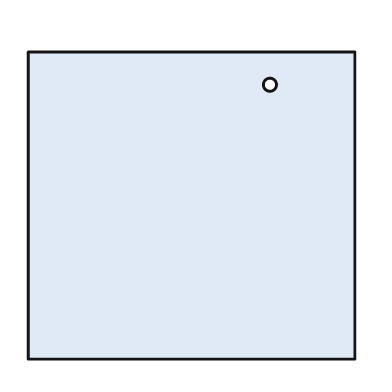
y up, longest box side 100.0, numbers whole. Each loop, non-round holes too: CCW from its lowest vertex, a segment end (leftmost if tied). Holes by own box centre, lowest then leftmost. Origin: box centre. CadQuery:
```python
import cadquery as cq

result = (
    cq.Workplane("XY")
    .moveTo(-50.0, -47.0)
    .lineTo(50.0, -47.0)
    .lineTo(50.0, 47.0)
    .lineTo(-50.0, 47.0)
    .close()
    .moveTo(24.0, 37.0)
    .circle(2.0)
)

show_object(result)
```